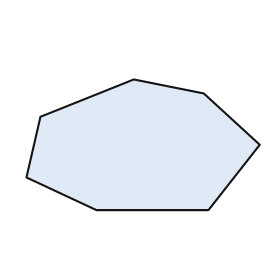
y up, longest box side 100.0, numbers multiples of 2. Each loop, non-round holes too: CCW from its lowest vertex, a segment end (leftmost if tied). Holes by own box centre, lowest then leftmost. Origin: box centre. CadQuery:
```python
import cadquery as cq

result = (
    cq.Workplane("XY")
    .moveTo(-20.0, -28.0)
    .lineTo(28.0, -28.0)
    .lineTo(50.0, 0.0)
    .lineTo(26.0, 22.0)
    .lineTo(-4.0, 28.0)
    .lineTo(-44.0, 12.0)
    .lineTo(-50.0, -14.0)
    .close()
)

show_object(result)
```